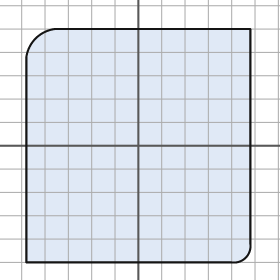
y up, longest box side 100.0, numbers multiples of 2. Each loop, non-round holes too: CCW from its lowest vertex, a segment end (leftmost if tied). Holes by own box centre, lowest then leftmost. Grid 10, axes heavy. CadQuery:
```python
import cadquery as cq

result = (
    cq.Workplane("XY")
    .moveTo(-48.0, -50.0)
    .lineTo(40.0, -50.0)
    .threePointArc((46.0, -48.0), (48.0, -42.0))
    .lineTo(48.0, 50.0)
    .lineTo(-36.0, 50.0)
    .threePointArc((-44.0, 46.0), (-48.0, 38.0))
    .close()
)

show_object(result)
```